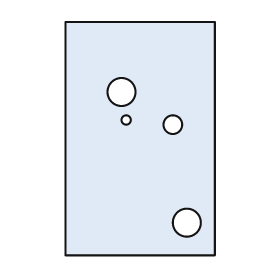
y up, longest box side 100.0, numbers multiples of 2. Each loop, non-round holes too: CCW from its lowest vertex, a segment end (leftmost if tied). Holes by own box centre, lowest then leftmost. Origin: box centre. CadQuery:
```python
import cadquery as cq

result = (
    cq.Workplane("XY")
    .moveTo(-32.0, -50.0)
    .lineTo(32.0, -50.0)
    .lineTo(32.0, 50.0)
    .lineTo(-32.0, 50.0)
    .close()
    .moveTo(20.0, -36.0)
    .circle(6.0)
    .moveTo(14.0, 6.0)
    .circle(4.0)
    .moveTo(-6.0, 8.0)
    .circle(2.0)
    .moveTo(-8.0, 20.0)
    .circle(6.0)
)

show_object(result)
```